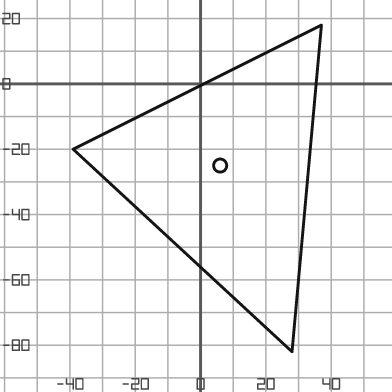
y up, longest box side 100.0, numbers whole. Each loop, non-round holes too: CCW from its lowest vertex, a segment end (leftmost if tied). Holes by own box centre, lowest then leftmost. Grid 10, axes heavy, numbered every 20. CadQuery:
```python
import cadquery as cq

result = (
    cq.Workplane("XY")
    .moveTo(28.0, -82.0)
    .lineTo(37.0, 18.0)
    .lineTo(-39.0, -20.0)
    .close()
    .moveTo(6.0, -25.0)
    .circle(2.0)
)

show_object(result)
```